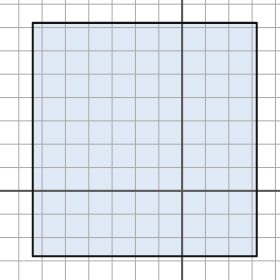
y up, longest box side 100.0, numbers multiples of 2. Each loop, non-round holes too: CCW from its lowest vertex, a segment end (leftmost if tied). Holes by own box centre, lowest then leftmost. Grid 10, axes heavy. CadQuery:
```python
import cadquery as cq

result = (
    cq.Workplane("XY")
    .moveTo(-64.0, -28.0)
    .lineTo(32.0, -28.0)
    .lineTo(32.0, 72.0)
    .lineTo(-64.0, 72.0)
    .close()
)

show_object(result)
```